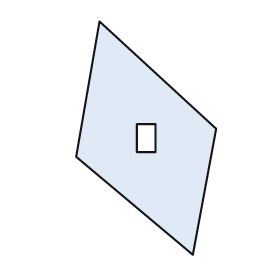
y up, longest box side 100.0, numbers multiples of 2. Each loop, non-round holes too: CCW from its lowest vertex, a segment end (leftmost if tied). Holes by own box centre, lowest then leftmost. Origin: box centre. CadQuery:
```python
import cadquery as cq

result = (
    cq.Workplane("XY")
    .moveTo(20.0, -50.0)
    .lineTo(30.0, 4.0)
    .lineTo(-20.0, 50.0)
    .lineTo(-30.0, -8.0)
    .close()
    .moveTo(-4.0, -6.0)
    .lineTo(4.0, -6.0)
    .lineTo(4.0, 6.0)
    .lineTo(-4.0, 6.0)
    .close()
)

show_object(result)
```